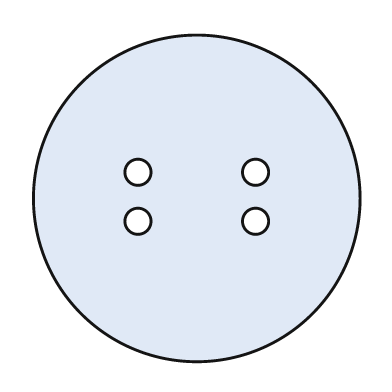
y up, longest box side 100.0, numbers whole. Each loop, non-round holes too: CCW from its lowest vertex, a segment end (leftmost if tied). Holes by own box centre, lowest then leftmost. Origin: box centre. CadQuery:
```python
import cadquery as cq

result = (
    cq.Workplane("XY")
    .moveTo(0.0, 0.0)
    .circle(50.0)
    .moveTo(-18.0, -7.0)
    .circle(4.0)
    .moveTo(18.0, -7.0)
    .circle(4.0)
    .moveTo(-18.0, 8.0)
    .circle(4.0)
    .moveTo(18.0, 8.0)
    .circle(4.0)
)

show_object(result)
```